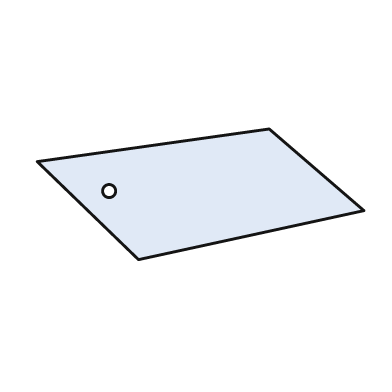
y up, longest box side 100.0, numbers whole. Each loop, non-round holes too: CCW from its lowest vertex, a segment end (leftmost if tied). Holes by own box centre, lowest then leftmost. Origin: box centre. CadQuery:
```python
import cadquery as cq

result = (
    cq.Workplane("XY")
    .moveTo(-19.0, -20.0)
    .lineTo(50.0, -5.0)
    .lineTo(21.0, 20.0)
    .lineTo(-50.0, 10.0)
    .close()
    .moveTo(-28.0, 1.0)
    .circle(2.0)
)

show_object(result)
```